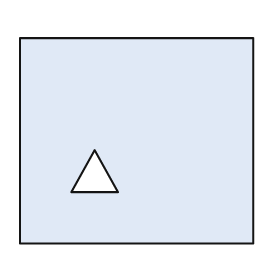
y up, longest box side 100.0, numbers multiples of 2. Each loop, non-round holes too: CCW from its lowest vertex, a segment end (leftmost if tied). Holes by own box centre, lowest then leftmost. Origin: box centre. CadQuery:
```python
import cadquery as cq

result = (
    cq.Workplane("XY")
    .moveTo(-50.0, -44.0)
    .lineTo(50.0, -44.0)
    .lineTo(50.0, 44.0)
    .lineTo(-50.0, 44.0)
    .close()
    .moveTo(-28.0, -22.0)
    .lineTo(-8.0, -22.0)
    .lineTo(-18.0, -4.0)
    .close()
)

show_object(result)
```